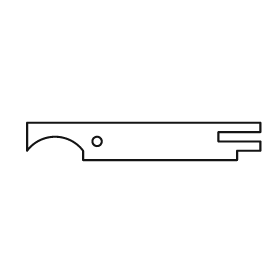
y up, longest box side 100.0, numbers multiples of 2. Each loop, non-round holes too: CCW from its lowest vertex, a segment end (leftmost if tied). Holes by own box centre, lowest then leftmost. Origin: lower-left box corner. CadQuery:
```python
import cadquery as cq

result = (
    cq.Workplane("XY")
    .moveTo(24.0, 0.0)
    .lineTo(90.0, 0.0)
    .lineTo(90.0, 4.0)
    .lineTo(100.0, 4.0)
    .lineTo(100.0, 8.0)
    .lineTo(82.0, 8.0)
    .lineTo(82.0, 12.0)
    .lineTo(100.0, 12.0)
    .lineTo(100.0, 16.0)
    .lineTo(0.0, 16.0)
    .lineTo(0.0, 4.0)
    .threePointArc((12.0, 10.0), (24.0, 4.0))
    .close()
    .moveTo(30.0, 8.0)
    .circle(2.0)
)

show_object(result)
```